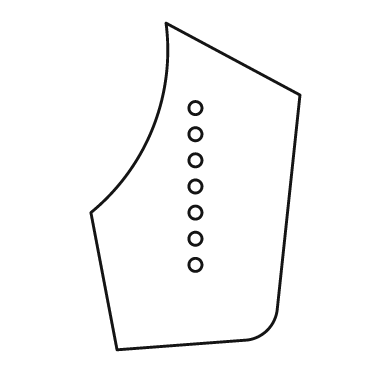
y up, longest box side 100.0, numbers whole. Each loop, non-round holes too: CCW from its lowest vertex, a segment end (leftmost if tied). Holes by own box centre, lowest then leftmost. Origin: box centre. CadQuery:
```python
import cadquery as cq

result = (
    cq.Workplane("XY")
    .moveTo(-24.0, -50.0)
    .lineTo(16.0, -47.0)
    .threePointArc((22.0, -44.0), (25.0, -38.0))
    .lineTo(32.0, 28.0)
    .lineTo(-9.0, 50.0)
    .threePointArc((-13.0, 18.0), (-32.0, -8.0))
    .close()
    .moveTo(0.0, -24.0)
    .circle(2.0)
    .moveTo(0.0, -16.0)
    .circle(2.0)
    .moveTo(0.0, -8.0)
    .circle(2.0)
    .moveTo(0.0, 0.0)
    .circle(2.0)
    .moveTo(0.0, 8.0)
    .circle(2.0)
    .moveTo(0.0, 16.0)
    .circle(2.0)
    .moveTo(0.0, 24.0)
    .circle(2.0)
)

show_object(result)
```